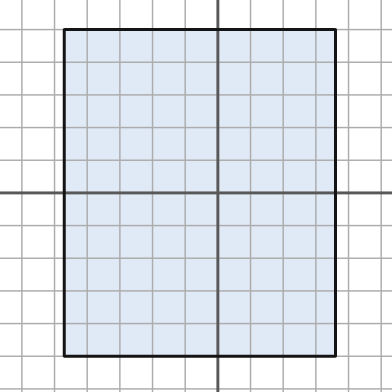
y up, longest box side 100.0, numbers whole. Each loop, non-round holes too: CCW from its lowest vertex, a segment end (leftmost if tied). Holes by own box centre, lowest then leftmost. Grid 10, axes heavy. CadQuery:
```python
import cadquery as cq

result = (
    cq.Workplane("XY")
    .moveTo(-47.0, -50.0)
    .lineTo(36.0, -50.0)
    .lineTo(36.0, 50.0)
    .lineTo(-47.0, 50.0)
    .close()
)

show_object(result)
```